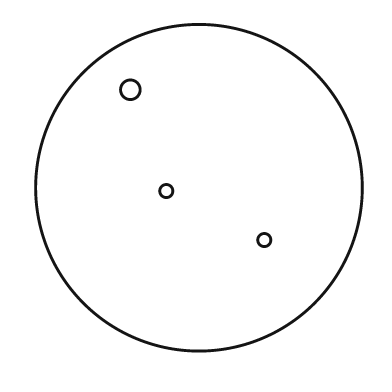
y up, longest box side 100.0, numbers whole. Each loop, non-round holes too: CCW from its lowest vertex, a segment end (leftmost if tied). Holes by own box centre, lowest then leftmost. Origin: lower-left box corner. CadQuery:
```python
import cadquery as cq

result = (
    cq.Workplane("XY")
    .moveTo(50.0, 50.0)
    .circle(50.0)
    .moveTo(70.0, 34.0)
    .circle(2.0)
    .moveTo(40.0, 49.0)
    .circle(2.0)
    .moveTo(29.0, 80.0)
    .circle(3.0)
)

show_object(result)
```